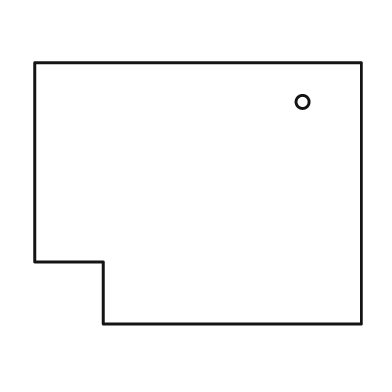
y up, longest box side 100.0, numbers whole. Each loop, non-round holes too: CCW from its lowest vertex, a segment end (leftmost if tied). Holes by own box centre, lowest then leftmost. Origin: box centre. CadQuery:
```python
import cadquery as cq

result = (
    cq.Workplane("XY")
    .moveTo(-29.0, -40.0)
    .lineTo(50.0, -40.0)
    .lineTo(50.0, 40.0)
    .lineTo(-50.0, 40.0)
    .lineTo(-50.0, -21.0)
    .lineTo(-29.0, -21.0)
    .close()
    .moveTo(32.0, 28.0)
    .circle(2.0)
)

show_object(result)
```